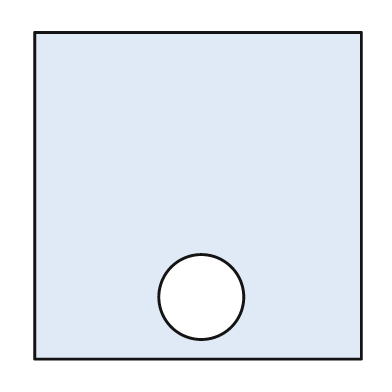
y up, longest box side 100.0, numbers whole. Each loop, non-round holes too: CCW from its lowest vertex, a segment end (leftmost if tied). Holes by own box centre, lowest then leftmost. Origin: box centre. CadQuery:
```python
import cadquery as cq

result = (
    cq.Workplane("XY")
    .moveTo(-50.0, -50.0)
    .lineTo(50.0, -50.0)
    .lineTo(50.0, 50.0)
    .lineTo(-50.0, 50.0)
    .close()
    .moveTo(1.0, -31.0)
    .circle(13.0)
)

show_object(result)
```